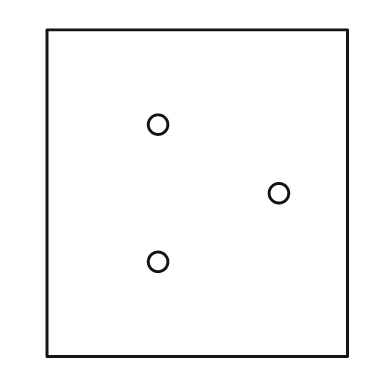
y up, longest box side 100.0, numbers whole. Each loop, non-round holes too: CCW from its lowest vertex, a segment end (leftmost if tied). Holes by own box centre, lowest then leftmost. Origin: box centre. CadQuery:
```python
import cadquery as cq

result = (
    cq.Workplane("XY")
    .moveTo(-46.0, -50.0)
    .lineTo(46.0, -50.0)
    .lineTo(46.0, 50.0)
    .lineTo(-46.0, 50.0)
    .close()
    .moveTo(-12.0, -21.0)
    .circle(3.0)
    .moveTo(25.0, 0.0)
    .circle(3.0)
    .moveTo(-12.0, 21.0)
    .circle(3.0)
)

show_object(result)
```